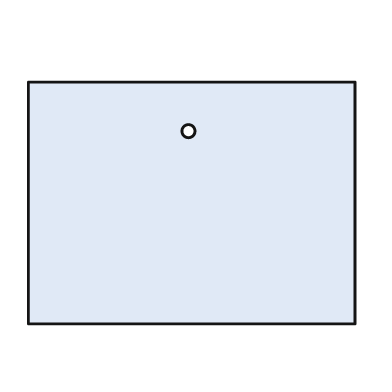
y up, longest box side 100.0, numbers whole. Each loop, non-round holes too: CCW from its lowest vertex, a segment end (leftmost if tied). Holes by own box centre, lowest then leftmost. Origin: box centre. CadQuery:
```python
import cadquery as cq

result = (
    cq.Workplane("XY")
    .moveTo(-50.0, -37.0)
    .lineTo(50.0, -37.0)
    .lineTo(50.0, 37.0)
    .lineTo(-50.0, 37.0)
    .close()
    .moveTo(-1.0, 22.0)
    .circle(2.0)
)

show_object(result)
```